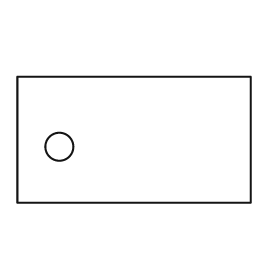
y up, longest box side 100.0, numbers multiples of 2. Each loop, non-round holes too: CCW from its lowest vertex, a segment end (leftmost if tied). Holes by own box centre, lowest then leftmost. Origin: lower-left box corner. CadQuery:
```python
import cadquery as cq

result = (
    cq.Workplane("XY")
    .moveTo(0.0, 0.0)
    .lineTo(100.0, 0.0)
    .lineTo(100.0, 54.0)
    .lineTo(0.0, 54.0)
    .close()
    .moveTo(18.0, 24.0)
    .circle(6.0)
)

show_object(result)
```